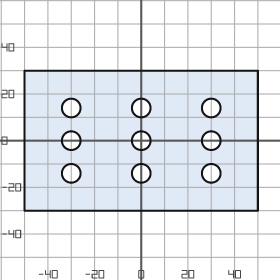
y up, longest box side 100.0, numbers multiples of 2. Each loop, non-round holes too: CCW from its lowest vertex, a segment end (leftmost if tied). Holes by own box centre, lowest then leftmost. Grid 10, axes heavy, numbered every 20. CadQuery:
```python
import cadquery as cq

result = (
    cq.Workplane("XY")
    .moveTo(-50.0, -30.0)
    .lineTo(50.0, -30.0)
    .lineTo(50.0, 30.0)
    .lineTo(-50.0, 30.0)
    .close()
    .moveTo(-30.0, -14.0)
    .circle(4.0)
    .moveTo(0.0, -14.0)
    .circle(4.0)
    .moveTo(30.0, -14.0)
    .circle(4.0)
    .moveTo(-30.0, 0.0)
    .circle(4.0)
    .moveTo(0.0, 0.0)
    .circle(4.0)
    .moveTo(30.0, 0.0)
    .circle(4.0)
    .moveTo(-30.0, 14.0)
    .circle(4.0)
    .moveTo(0.0, 14.0)
    .circle(4.0)
    .moveTo(30.0, 14.0)
    .circle(4.0)
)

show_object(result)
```